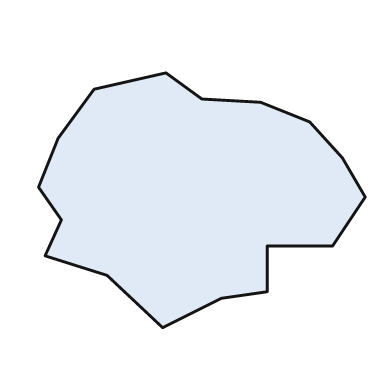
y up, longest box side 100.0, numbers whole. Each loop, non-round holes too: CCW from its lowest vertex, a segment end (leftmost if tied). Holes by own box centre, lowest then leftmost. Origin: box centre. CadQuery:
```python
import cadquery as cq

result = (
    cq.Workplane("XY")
    .moveTo(-12.0, -39.0)
    .lineTo(6.0, -30.0)
    .lineTo(20.0, -28.0)
    .lineTo(20.0, -14.0)
    .lineTo(40.0, -14.0)
    .lineTo(50.0, 1.0)
    .lineTo(43.0, 13.0)
    .lineTo(33.0, 24.0)
    .lineTo(18.0, 30.0)
    .lineTo(0.0, 31.0)
    .lineTo(-11.0, 39.0)
    .lineTo(-33.0, 34.0)
    .lineTo(-44.0, 19.0)
    .lineTo(-50.0, 4.0)
    .lineTo(-43.0, -6.0)
    .lineTo(-48.0, -17.0)
    .lineTo(-29.0, -23.0)
    .close()
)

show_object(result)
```